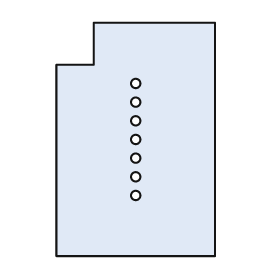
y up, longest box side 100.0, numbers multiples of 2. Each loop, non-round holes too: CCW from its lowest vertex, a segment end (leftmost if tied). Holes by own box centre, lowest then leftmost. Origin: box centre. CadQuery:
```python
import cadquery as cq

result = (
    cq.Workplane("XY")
    .moveTo(-34.0, -50.0)
    .lineTo(34.0, -50.0)
    .lineTo(34.0, 50.0)
    .lineTo(-18.0, 50.0)
    .lineTo(-18.0, 32.0)
    .lineTo(-34.0, 32.0)
    .close()
    .moveTo(0.0, -24.0)
    .circle(2.0)
    .moveTo(0.0, -16.0)
    .circle(2.0)
    .moveTo(0.0, -8.0)
    .circle(2.0)
    .moveTo(0.0, 0.0)
    .circle(2.0)
    .moveTo(0.0, 8.0)
    .circle(2.0)
    .moveTo(0.0, 16.0)
    .circle(2.0)
    .moveTo(0.0, 24.0)
    .circle(2.0)
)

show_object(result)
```